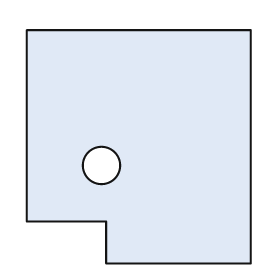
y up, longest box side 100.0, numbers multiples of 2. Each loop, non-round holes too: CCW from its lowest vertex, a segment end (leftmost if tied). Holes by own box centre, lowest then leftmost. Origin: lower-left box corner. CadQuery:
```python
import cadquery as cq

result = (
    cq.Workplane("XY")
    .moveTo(34.0, 0.0)
    .lineTo(96.0, 0.0)
    .lineTo(96.0, 100.0)
    .lineTo(0.0, 100.0)
    .lineTo(0.0, 18.0)
    .lineTo(34.0, 18.0)
    .close()
    .moveTo(32.0, 42.0)
    .circle(8.0)
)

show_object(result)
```